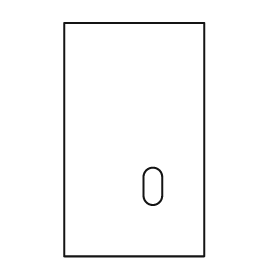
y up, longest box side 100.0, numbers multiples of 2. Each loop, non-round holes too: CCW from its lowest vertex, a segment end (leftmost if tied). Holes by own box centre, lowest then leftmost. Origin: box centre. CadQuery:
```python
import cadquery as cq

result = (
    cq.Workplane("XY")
    .moveTo(-30.0, -50.0)
    .lineTo(30.0, -50.0)
    .lineTo(30.0, 50.0)
    .lineTo(-30.0, 50.0)
    .close()
    .moveTo(4.0, -24.0)
    .threePointArc((8.0, -28.0), (12.0, -24.0))
    .lineTo(12.0, -16.0)
    .threePointArc((8.0, -12.0), (4.0, -16.0))
    .close()
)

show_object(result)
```